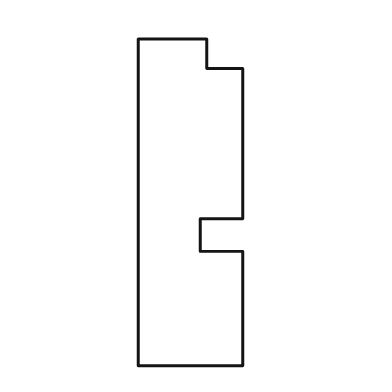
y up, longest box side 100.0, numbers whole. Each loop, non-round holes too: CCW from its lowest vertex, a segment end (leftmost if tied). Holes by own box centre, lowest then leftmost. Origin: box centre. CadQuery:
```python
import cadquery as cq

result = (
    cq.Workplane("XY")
    .moveTo(-16.0, -50.0)
    .lineTo(16.0, -50.0)
    .lineTo(16.0, -15.0)
    .lineTo(3.0, -15.0)
    .lineTo(3.0, -5.0)
    .lineTo(16.0, -5.0)
    .lineTo(16.0, 41.0)
    .lineTo(5.0, 41.0)
    .lineTo(5.0, 50.0)
    .lineTo(-16.0, 50.0)
    .close()
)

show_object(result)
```